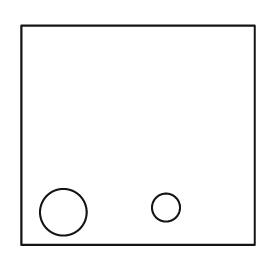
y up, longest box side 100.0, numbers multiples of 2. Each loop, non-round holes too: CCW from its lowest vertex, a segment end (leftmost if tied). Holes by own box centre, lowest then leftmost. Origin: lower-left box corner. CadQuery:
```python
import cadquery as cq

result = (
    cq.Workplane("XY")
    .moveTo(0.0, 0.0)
    .lineTo(100.0, 0.0)
    .lineTo(100.0, 94.0)
    .lineTo(0.0, 94.0)
    .close()
    .moveTo(18.0, 14.0)
    .circle(10.0)
    .moveTo(62.0, 16.0)
    .circle(6.0)
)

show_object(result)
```